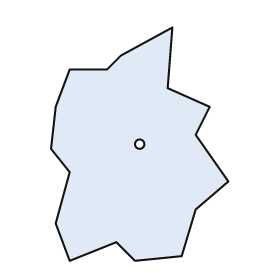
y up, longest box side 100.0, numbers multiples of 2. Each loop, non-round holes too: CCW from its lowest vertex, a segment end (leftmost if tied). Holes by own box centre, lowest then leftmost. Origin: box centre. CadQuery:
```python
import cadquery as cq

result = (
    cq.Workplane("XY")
    .moveTo(-30.0, -50.0)
    .lineTo(-10.0, -42.0)
    .lineTo(-2.0, -50.0)
    .lineTo(18.0, -48.0)
    .lineTo(24.0, -28.0)
    .lineTo(38.0, -16.0)
    .lineTo(24.0, 4.0)
    .lineTo(30.0, 16.0)
    .lineTo(12.0, 24.0)
    .lineTo(14.0, 50.0)
    .lineTo(-8.0, 38.0)
    .lineTo(-14.0, 32.0)
    .lineTo(-30.0, 32.0)
    .lineTo(-36.0, 16.0)
    .lineTo(-38.0, -2.0)
    .lineTo(-30.0, -12.0)
    .lineTo(-36.0, -34.0)
    .close()
    .moveTo(0.0, 0.0)
    .circle(2.0)
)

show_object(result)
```